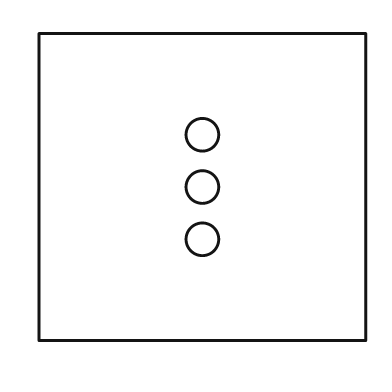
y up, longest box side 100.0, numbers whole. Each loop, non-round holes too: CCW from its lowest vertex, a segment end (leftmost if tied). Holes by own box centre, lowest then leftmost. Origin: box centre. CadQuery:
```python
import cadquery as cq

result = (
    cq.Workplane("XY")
    .moveTo(-50.0, -47.0)
    .lineTo(50.0, -47.0)
    .lineTo(50.0, 47.0)
    .lineTo(-50.0, 47.0)
    .close()
    .moveTo(0.0, -16.0)
    .circle(5.0)
    .moveTo(0.0, 0.0)
    .circle(5.0)
    .moveTo(0.0, 16.0)
    .circle(5.0)
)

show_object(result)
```